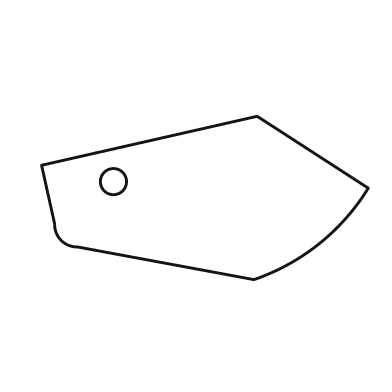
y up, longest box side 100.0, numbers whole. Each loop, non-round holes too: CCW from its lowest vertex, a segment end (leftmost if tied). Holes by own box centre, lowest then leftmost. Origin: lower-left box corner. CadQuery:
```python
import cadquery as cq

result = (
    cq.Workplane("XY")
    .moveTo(65.0, 0.0)
    .threePointArc((85.0, 11.0), (100.0, 28.0))
    .lineTo(66.0, 50.0)
    .lineTo(0.0, 35.0)
    .lineTo(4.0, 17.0)
    .threePointArc((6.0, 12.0), (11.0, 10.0))
    .close()
    .moveTo(22.0, 30.0)
    .circle(4.0)
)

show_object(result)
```